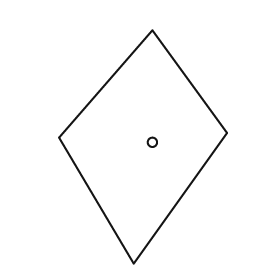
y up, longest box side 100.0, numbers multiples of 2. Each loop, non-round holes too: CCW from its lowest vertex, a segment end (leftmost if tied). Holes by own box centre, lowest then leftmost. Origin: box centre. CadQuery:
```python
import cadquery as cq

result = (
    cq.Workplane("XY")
    .moveTo(-4.0, -50.0)
    .lineTo(36.0, 6.0)
    .lineTo(4.0, 50.0)
    .lineTo(-36.0, 4.0)
    .close()
    .moveTo(4.0, 2.0)
    .circle(2.0)
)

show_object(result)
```